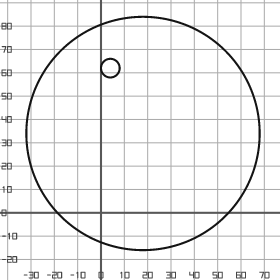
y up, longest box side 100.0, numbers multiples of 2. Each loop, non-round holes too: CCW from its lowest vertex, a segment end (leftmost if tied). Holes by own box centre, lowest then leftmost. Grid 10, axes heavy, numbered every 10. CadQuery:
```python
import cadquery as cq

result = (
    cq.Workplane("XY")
    .moveTo(18.0, 34.0)
    .circle(50.0)
    .moveTo(4.0, 62.0)
    .circle(4.0)
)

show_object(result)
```